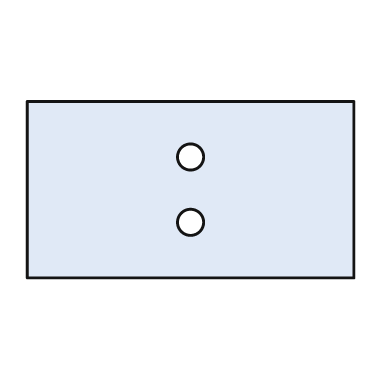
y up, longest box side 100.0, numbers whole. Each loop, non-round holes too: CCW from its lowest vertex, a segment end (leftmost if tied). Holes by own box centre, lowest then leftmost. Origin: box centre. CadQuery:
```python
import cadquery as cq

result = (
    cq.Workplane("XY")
    .moveTo(-50.0, -27.0)
    .lineTo(50.0, -27.0)
    .lineTo(50.0, 27.0)
    .lineTo(-50.0, 27.0)
    .close()
    .moveTo(0.0, -10.0)
    .circle(4.0)
    .moveTo(0.0, 10.0)
    .circle(4.0)
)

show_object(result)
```